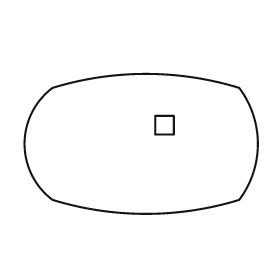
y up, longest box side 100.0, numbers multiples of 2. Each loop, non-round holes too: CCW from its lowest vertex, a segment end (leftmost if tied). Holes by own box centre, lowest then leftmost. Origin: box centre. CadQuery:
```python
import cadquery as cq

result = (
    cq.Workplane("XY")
    .moveTo(-38.0, -24.0)
    .threePointArc((2.0, -30.0), (42.0, -24.0))
    .threePointArc((50.0, 0.0), (42.0, 24.0))
    .threePointArc((2.0, 30.0), (-38.0, 24.0))
    .threePointArc((-50.0, 0.0), (-38.0, -24.0))
    .close()
    .moveTo(6.0, 4.0)
    .lineTo(14.0, 4.0)
    .lineTo(14.0, 12.0)
    .lineTo(6.0, 12.0)
    .close()
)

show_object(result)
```